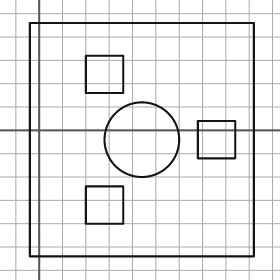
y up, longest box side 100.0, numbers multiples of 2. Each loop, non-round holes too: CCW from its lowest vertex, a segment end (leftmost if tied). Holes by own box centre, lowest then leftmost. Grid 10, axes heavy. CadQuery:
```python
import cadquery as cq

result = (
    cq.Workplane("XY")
    .moveTo(-4.0, -54.0)
    .lineTo(92.0, -54.0)
    .lineTo(92.0, 46.0)
    .lineTo(-4.0, 46.0)
    .close()
    .moveTo(20.0, -40.0)
    .lineTo(36.0, -40.0)
    .lineTo(36.0, -24.0)
    .lineTo(20.0, -24.0)
    .close()
    .moveTo(44.0, -4.0)
    .circle(16.0)
    .moveTo(68.0, -12.0)
    .lineTo(84.0, -12.0)
    .lineTo(84.0, 4.0)
    .lineTo(68.0, 4.0)
    .close()
    .moveTo(20.0, 16.0)
    .lineTo(36.0, 16.0)
    .lineTo(36.0, 32.0)
    .lineTo(20.0, 32.0)
    .close()
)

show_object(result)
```